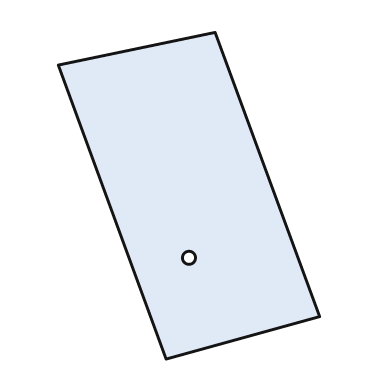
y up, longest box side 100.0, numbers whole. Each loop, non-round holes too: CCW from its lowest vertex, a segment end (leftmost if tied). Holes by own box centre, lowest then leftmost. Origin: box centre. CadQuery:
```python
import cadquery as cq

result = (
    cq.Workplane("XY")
    .moveTo(-7.0, -50.0)
    .lineTo(40.0, -37.0)
    .lineTo(8.0, 50.0)
    .lineTo(-40.0, 40.0)
    .close()
    .moveTo(0.0, -19.0)
    .circle(2.0)
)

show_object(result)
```